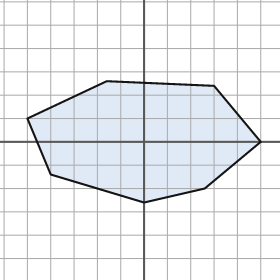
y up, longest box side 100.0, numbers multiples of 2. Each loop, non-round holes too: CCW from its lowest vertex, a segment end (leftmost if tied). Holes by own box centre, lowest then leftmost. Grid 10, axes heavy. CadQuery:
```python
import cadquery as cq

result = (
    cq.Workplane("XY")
    .moveTo(0.0, -26.0)
    .lineTo(26.0, -20.0)
    .lineTo(50.0, 0.0)
    .lineTo(30.0, 24.0)
    .lineTo(-16.0, 26.0)
    .lineTo(-50.0, 10.0)
    .lineTo(-40.0, -14.0)
    .close()
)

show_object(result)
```